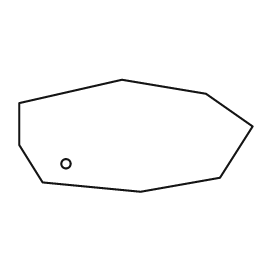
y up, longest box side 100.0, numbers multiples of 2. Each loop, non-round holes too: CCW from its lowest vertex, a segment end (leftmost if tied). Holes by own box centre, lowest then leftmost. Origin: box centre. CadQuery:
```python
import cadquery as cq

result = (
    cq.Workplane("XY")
    .moveTo(2.0, -24.0)
    .lineTo(36.0, -18.0)
    .lineTo(50.0, 4.0)
    .lineTo(30.0, 18.0)
    .lineTo(-6.0, 24.0)
    .lineTo(-50.0, 14.0)
    .lineTo(-50.0, -4.0)
    .lineTo(-40.0, -20.0)
    .close()
    .moveTo(-30.0, -12.0)
    .circle(2.0)
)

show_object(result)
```